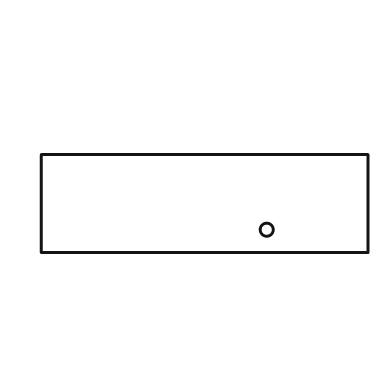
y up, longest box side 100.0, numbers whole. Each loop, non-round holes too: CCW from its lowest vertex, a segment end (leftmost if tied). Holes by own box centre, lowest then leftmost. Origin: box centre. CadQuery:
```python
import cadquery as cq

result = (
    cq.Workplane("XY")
    .moveTo(-50.0, -15.0)
    .lineTo(50.0, -15.0)
    .lineTo(50.0, 15.0)
    .lineTo(-50.0, 15.0)
    .close()
    .moveTo(19.0, -8.0)
    .circle(2.0)
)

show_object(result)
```